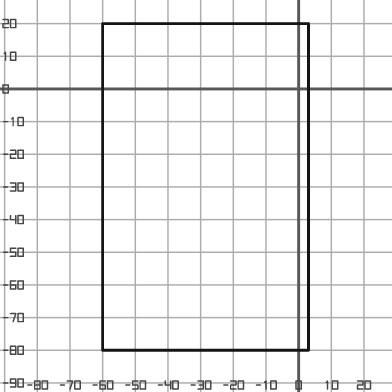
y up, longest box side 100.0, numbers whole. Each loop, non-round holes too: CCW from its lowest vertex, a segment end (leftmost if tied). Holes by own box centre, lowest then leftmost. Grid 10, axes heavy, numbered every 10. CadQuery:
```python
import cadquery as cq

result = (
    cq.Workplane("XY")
    .moveTo(-60.0, -80.0)
    .lineTo(3.0, -80.0)
    .lineTo(3.0, 20.0)
    .lineTo(-60.0, 20.0)
    .close()
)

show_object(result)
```